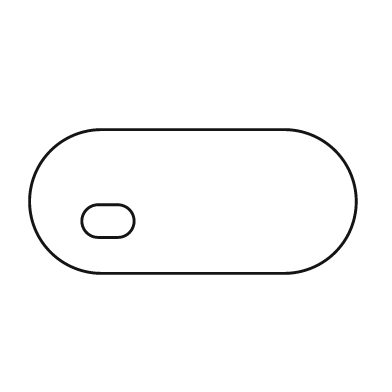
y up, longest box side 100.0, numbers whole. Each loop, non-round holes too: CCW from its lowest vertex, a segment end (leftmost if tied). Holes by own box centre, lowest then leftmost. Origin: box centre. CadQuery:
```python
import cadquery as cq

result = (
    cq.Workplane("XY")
    .moveTo(-28.0, -22.0)
    .lineTo(28.0, -22.0)
    .threePointArc((50.0, 0.0), (28.0, 22.0))
    .lineTo(-28.0, 22.0)
    .threePointArc((-50.0, 0.0), (-28.0, -22.0))
    .close()
    .moveTo(-29.0, -11.0)
    .lineTo(-23.0, -11.0)
    .threePointArc((-18.0, -6.0), (-23.0, -1.0))
    .lineTo(-29.0, -1.0)
    .threePointArc((-34.0, -6.0), (-29.0, -11.0))
    .close()
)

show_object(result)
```